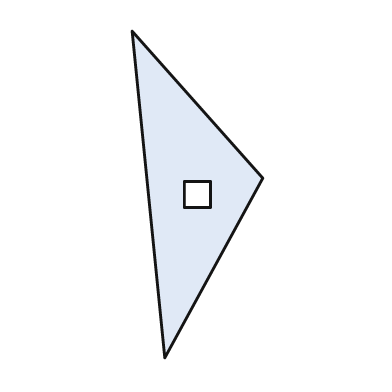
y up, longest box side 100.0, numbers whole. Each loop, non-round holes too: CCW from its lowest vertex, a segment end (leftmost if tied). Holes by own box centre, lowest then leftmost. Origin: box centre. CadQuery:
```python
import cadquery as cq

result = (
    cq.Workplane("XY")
    .moveTo(-10.0, -50.0)
    .lineTo(20.0, 5.0)
    .lineTo(-20.0, 50.0)
    .close()
    .moveTo(-4.0, -4.0)
    .lineTo(4.0, -4.0)
    .lineTo(4.0, 4.0)
    .lineTo(-4.0, 4.0)
    .close()
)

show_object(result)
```